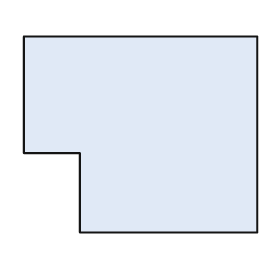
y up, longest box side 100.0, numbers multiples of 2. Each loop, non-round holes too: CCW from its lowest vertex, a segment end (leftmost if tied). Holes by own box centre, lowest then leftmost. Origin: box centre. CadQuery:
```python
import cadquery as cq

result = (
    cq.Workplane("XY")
    .moveTo(-26.0, -42.0)
    .lineTo(50.0, -42.0)
    .lineTo(50.0, 42.0)
    .lineTo(-50.0, 42.0)
    .lineTo(-50.0, -8.0)
    .lineTo(-26.0, -8.0)
    .close()
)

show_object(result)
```